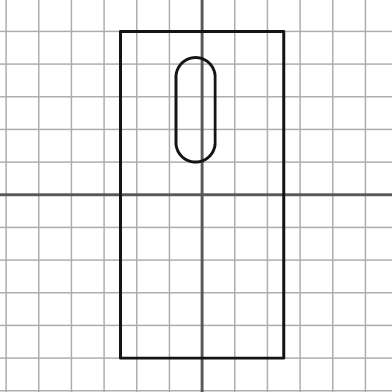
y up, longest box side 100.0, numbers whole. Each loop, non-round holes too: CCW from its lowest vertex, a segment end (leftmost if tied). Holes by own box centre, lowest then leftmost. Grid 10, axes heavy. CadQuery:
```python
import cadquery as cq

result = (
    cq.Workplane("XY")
    .moveTo(-25.0, -50.0)
    .lineTo(25.0, -50.0)
    .lineTo(25.0, 50.0)
    .lineTo(-25.0, 50.0)
    .close()
    .moveTo(-8.0, 16.0)
    .threePointArc((-2.0, 10.0), (4.0, 16.0))
    .lineTo(4.0, 36.0)
    .threePointArc((-2.0, 42.0), (-8.0, 36.0))
    .close()
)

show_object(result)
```